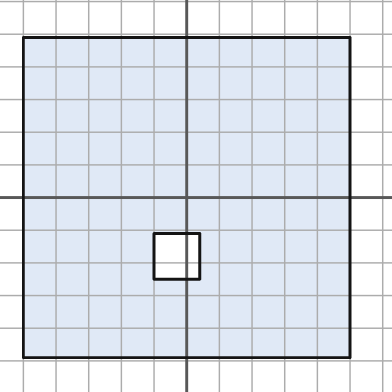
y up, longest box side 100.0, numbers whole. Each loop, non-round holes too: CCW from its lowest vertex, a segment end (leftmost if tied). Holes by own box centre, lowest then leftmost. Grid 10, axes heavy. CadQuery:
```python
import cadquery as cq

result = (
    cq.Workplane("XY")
    .moveTo(-50.0, -49.0)
    .lineTo(50.0, -49.0)
    .lineTo(50.0, 49.0)
    .lineTo(-50.0, 49.0)
    .close()
    .moveTo(-10.0, -25.0)
    .lineTo(4.0, -25.0)
    .lineTo(4.0, -11.0)
    .lineTo(-10.0, -11.0)
    .close()
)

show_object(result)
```